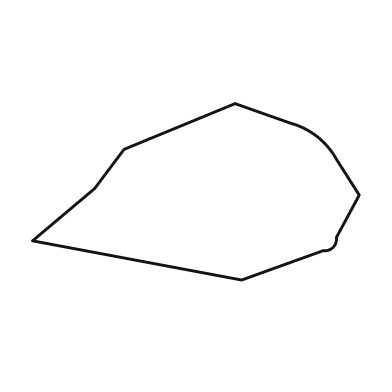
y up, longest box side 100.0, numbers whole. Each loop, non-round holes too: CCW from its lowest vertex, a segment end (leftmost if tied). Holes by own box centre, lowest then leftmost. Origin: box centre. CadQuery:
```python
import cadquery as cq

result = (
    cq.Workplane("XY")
    .moveTo(14.0, -27.0)
    .lineTo(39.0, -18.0)
    .threePointArc((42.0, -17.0), (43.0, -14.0))
    .lineTo(50.0, -1.0)
    .lineTo(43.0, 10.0)
    .threePointArc((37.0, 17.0), (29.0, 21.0))
    .lineTo(12.0, 27.0)
    .lineTo(-22.0, 13.0)
    .lineTo(-31.0, 1.0)
    .lineTo(-50.0, -15.0)
    .close()
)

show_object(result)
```